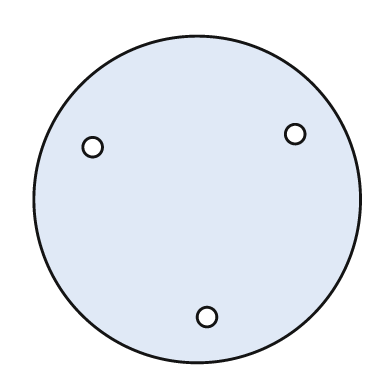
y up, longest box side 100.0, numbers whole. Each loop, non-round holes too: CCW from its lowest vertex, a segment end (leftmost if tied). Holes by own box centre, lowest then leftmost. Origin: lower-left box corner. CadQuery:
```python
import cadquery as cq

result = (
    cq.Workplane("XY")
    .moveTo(50.0, 50.0)
    .circle(50.0)
    .moveTo(53.0, 14.0)
    .circle(3.0)
    .moveTo(18.0, 66.0)
    .circle(3.0)
    .moveTo(80.0, 70.0)
    .circle(3.0)
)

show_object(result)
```